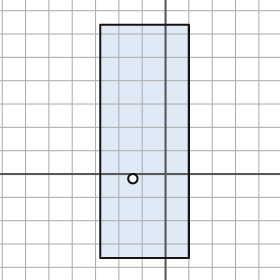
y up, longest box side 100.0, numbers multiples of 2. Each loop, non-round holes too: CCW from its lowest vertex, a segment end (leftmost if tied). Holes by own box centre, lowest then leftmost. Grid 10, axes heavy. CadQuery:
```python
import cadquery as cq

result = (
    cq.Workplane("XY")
    .moveTo(-28.0, -36.0)
    .lineTo(10.0, -36.0)
    .lineTo(10.0, 64.0)
    .lineTo(-28.0, 64.0)
    .close()
    .moveTo(-14.0, -2.0)
    .circle(2.0)
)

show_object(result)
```